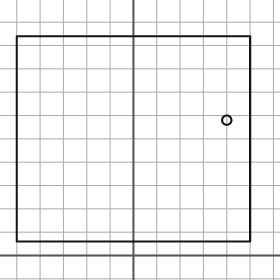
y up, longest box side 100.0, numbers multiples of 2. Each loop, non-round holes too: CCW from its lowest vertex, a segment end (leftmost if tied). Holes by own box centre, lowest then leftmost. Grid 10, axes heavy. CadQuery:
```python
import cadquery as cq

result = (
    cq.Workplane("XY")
    .moveTo(-50.0, 6.0)
    .lineTo(50.0, 6.0)
    .lineTo(50.0, 94.0)
    .lineTo(-50.0, 94.0)
    .close()
    .moveTo(40.0, 58.0)
    .circle(2.0)
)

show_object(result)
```